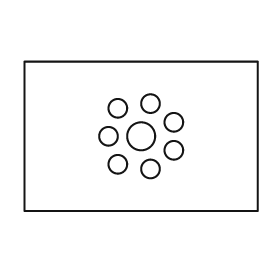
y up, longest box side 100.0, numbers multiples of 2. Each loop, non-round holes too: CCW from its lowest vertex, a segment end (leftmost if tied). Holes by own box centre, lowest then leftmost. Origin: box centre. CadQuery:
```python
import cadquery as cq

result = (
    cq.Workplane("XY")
    .moveTo(-50.0, -32.0)
    .lineTo(50.0, -32.0)
    .lineTo(50.0, 32.0)
    .lineTo(-50.0, 32.0)
    .close()
    .moveTo(4.0, -14.0)
    .circle(4.0)
    .moveTo(-10.0, -12.0)
    .circle(4.0)
    .moveTo(14.0, -6.0)
    .circle(4.0)
    .moveTo(-14.0, 0.0)
    .circle(4.0)
    .moveTo(0.0, 0.0)
    .circle(6.0)
    .moveTo(14.0, 6.0)
    .circle(4.0)
    .moveTo(-10.0, 12.0)
    .circle(4.0)
    .moveTo(4.0, 14.0)
    .circle(4.0)
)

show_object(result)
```